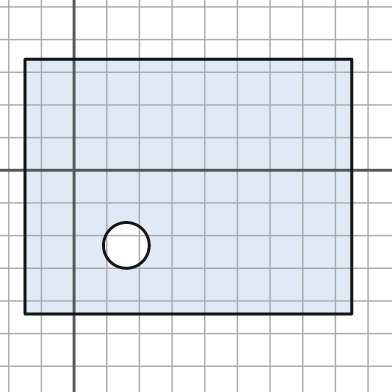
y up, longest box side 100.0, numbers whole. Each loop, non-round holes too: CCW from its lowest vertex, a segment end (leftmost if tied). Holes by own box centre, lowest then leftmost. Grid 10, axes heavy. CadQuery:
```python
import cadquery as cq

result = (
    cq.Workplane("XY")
    .moveTo(-15.0, -44.0)
    .lineTo(85.0, -44.0)
    .lineTo(85.0, 34.0)
    .lineTo(-15.0, 34.0)
    .close()
    .moveTo(16.0, -23.0)
    .circle(7.0)
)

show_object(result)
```